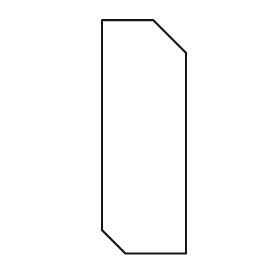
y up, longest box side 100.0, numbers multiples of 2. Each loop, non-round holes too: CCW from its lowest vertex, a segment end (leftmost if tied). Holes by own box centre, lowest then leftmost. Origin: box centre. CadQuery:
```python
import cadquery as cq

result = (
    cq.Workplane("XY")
    .moveTo(-8.0, -50.0)
    .lineTo(18.0, -50.0)
    .lineTo(18.0, 36.0)
    .lineTo(4.0, 50.0)
    .lineTo(-18.0, 50.0)
    .lineTo(-18.0, -40.0)
    .close()
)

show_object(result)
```